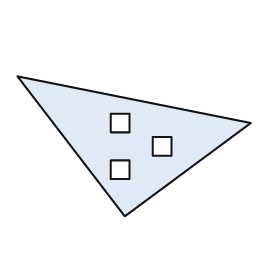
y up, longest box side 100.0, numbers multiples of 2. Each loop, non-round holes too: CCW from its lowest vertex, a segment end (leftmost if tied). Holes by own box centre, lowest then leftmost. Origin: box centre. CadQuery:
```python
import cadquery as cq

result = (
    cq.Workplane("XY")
    .moveTo(-4.0, -30.0)
    .lineTo(50.0, 10.0)
    .lineTo(-50.0, 30.0)
    .close()
    .moveTo(-10.0, -14.0)
    .lineTo(-2.0, -14.0)
    .lineTo(-2.0, -6.0)
    .lineTo(-10.0, -6.0)
    .close()
    .moveTo(8.0, -4.0)
    .lineTo(16.0, -4.0)
    .lineTo(16.0, 4.0)
    .lineTo(8.0, 4.0)
    .close()
    .moveTo(-10.0, 6.0)
    .lineTo(-2.0, 6.0)
    .lineTo(-2.0, 14.0)
    .lineTo(-10.0, 14.0)
    .close()
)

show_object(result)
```